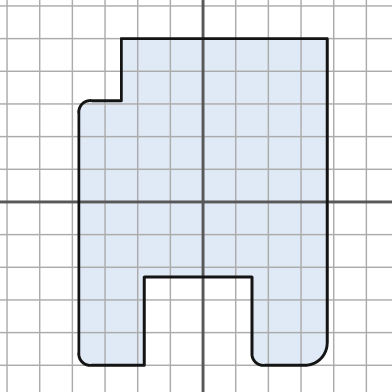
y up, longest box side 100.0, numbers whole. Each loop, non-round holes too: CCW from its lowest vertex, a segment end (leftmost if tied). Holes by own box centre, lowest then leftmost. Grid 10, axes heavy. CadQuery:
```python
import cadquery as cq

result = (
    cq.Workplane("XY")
    .moveTo(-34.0, -50.0)
    .lineTo(-18.0, -50.0)
    .lineTo(-18.0, -23.0)
    .lineTo(15.0, -23.0)
    .lineTo(15.0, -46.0)
    .threePointArc((16.0, -49.0), (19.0, -50.0))
    .lineTo(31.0, -50.0)
    .threePointArc((36.0, -48.0), (38.0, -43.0))
    .lineTo(38.0, 50.0)
    .lineTo(-25.0, 50.0)
    .lineTo(-25.0, 31.0)
    .lineTo(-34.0, 31.0)
    .threePointArc((-37.0, 30.0), (-38.0, 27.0))
    .lineTo(-38.0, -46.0)
    .threePointArc((-37.0, -49.0), (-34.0, -50.0))
    .close()
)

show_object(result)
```